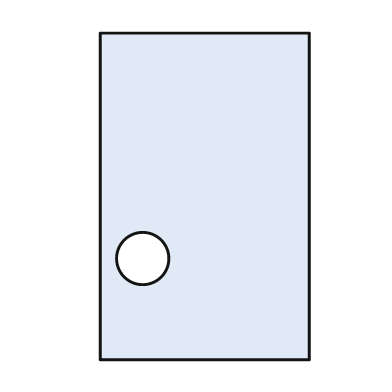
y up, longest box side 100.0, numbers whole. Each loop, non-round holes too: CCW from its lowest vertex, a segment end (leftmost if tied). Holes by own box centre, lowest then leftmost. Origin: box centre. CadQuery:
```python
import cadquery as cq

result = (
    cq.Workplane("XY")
    .moveTo(-32.0, -50.0)
    .lineTo(32.0, -50.0)
    .lineTo(32.0, 50.0)
    .lineTo(-32.0, 50.0)
    .close()
    .moveTo(-19.0, -19.0)
    .circle(8.0)
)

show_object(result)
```